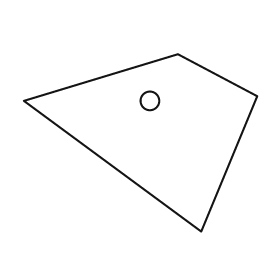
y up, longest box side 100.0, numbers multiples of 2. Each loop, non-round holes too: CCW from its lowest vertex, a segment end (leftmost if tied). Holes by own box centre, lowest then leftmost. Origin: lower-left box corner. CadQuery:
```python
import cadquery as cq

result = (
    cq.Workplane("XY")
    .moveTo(76.0, 0.0)
    .lineTo(100.0, 58.0)
    .lineTo(66.0, 76.0)
    .lineTo(0.0, 56.0)
    .close()
    .moveTo(54.0, 56.0)
    .circle(4.0)
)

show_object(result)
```